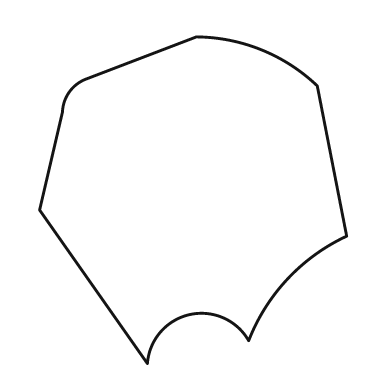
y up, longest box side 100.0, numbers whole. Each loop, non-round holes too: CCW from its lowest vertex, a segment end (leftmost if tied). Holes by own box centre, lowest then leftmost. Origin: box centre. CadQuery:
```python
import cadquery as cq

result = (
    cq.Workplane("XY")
    .moveTo(-14.0, -50.0)
    .threePointArc((-1.0, -35.0), (17.0, -43.0))
    .threePointArc((29.0, -24.0), (47.0, -11.0))
    .lineTo(38.0, 35.0)
    .threePointArc((21.0, 46.0), (1.0, 50.0))
    .lineTo(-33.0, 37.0)
    .threePointArc((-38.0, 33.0), (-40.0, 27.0))
    .lineTo(-47.0, -3.0)
    .close()
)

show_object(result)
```